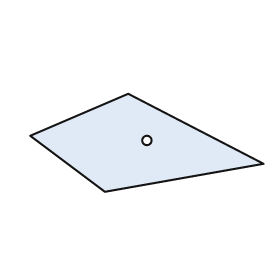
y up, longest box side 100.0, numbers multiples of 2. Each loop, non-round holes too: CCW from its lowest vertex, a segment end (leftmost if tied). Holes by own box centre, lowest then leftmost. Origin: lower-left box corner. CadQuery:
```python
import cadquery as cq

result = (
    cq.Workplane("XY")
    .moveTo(32.0, 0.0)
    .lineTo(100.0, 12.0)
    .lineTo(42.0, 42.0)
    .lineTo(0.0, 24.0)
    .close()
    .moveTo(50.0, 22.0)
    .circle(2.0)
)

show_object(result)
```